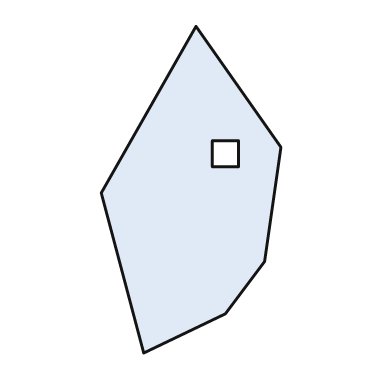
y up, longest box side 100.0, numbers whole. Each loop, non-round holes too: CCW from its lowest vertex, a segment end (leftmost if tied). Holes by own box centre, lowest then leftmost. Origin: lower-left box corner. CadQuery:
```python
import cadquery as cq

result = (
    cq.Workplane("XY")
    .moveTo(13.0, 0.0)
    .lineTo(38.0, 12.0)
    .lineTo(50.0, 28.0)
    .lineTo(55.0, 63.0)
    .lineTo(29.0, 100.0)
    .lineTo(0.0, 49.0)
    .close()
    .moveTo(34.0, 57.0)
    .lineTo(42.0, 57.0)
    .lineTo(42.0, 65.0)
    .lineTo(34.0, 65.0)
    .close()
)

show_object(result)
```